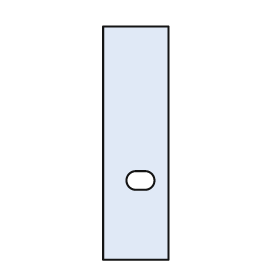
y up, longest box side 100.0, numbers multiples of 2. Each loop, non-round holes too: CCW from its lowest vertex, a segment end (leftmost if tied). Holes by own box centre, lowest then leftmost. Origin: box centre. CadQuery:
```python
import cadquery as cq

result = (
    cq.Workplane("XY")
    .moveTo(-14.0, -50.0)
    .lineTo(14.0, -50.0)
    .lineTo(14.0, 50.0)
    .lineTo(-14.0, 50.0)
    .close()
    .moveTo(0.0, -20.0)
    .lineTo(4.0, -20.0)
    .threePointArc((8.0, -16.0), (4.0, -12.0))
    .lineTo(0.0, -12.0)
    .threePointArc((-4.0, -16.0), (0.0, -20.0))
    .close()
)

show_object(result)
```